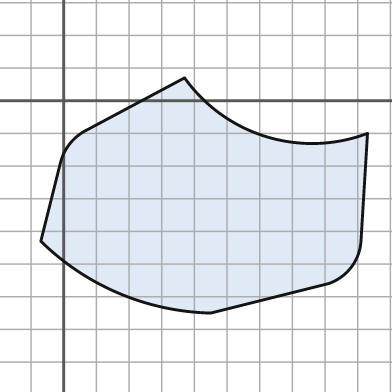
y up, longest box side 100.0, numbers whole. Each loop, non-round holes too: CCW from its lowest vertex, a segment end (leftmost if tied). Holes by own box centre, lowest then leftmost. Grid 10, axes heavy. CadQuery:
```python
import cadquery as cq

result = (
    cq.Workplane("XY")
    .moveTo(45.0, -65.0)
    .lineTo(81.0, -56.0)
    .threePointArc((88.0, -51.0), (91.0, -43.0))
    .lineTo(93.0, -10.0)
    .threePointArc((62.0, -11.0), (37.0, 7.0))
    .lineTo(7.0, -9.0)
    .threePointArc((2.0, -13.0), (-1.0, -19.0))
    .lineTo(-7.0, -43.0)
    .threePointArc((17.0, -59.0), (45.0, -65.0))
    .close()
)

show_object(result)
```